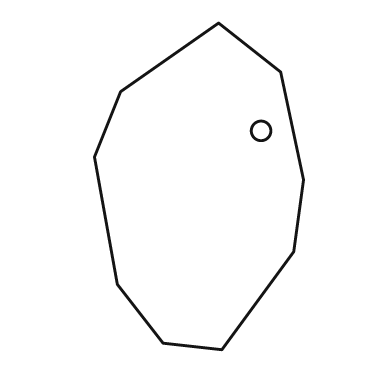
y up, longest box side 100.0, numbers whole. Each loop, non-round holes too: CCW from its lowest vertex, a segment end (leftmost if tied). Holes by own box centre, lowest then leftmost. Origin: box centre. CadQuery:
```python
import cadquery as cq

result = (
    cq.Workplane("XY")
    .moveTo(7.0, -50.0)
    .lineTo(29.0, -20.0)
    .lineTo(32.0, 2.0)
    .lineTo(25.0, 35.0)
    .lineTo(6.0, 50.0)
    .lineTo(-24.0, 29.0)
    .lineTo(-32.0, 9.0)
    .lineTo(-25.0, -30.0)
    .lineTo(-11.0, -48.0)
    .close()
    .moveTo(19.0, 17.0)
    .circle(3.0)
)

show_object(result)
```